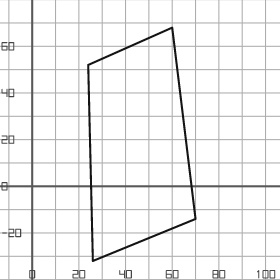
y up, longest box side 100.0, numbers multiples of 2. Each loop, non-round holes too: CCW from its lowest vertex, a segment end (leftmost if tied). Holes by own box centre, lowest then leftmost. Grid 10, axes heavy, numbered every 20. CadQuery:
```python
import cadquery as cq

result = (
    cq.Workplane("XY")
    .moveTo(26.0, -32.0)
    .lineTo(70.0, -14.0)
    .lineTo(60.0, 68.0)
    .lineTo(24.0, 52.0)
    .close()
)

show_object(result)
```